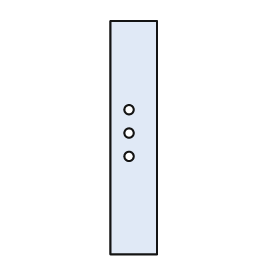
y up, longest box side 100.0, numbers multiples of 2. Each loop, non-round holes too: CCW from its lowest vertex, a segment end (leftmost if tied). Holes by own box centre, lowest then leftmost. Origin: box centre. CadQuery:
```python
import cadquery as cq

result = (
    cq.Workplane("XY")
    .moveTo(-10.0, -50.0)
    .lineTo(10.0, -50.0)
    .lineTo(10.0, 50.0)
    .lineTo(-10.0, 50.0)
    .close()
    .moveTo(-2.0, -8.0)
    .circle(2.0)
    .moveTo(-2.0, 2.0)
    .circle(2.0)
    .moveTo(-2.0, 12.0)
    .circle(2.0)
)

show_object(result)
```